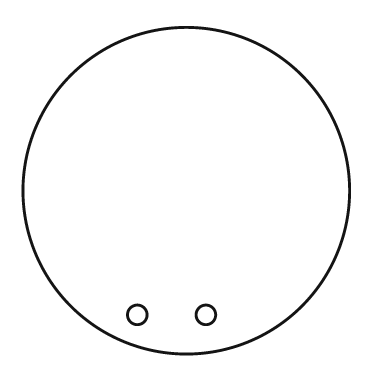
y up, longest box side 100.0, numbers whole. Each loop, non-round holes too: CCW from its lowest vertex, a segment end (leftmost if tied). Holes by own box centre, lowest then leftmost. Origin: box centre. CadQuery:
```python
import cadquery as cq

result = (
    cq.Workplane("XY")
    .moveTo(0.0, 0.0)
    .circle(50.0)
    .moveTo(-15.0, -38.0)
    .circle(3.0)
    .moveTo(6.0, -38.0)
    .circle(3.0)
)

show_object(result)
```